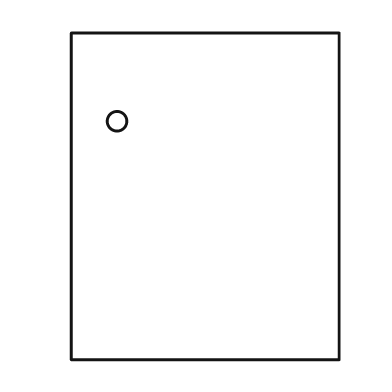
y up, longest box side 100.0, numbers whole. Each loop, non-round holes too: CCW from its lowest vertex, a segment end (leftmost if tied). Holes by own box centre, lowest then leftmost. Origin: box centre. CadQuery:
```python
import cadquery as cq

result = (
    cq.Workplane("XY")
    .moveTo(-41.0, -50.0)
    .lineTo(41.0, -50.0)
    .lineTo(41.0, 50.0)
    .lineTo(-41.0, 50.0)
    .close()
    .moveTo(-27.0, 23.0)
    .circle(3.0)
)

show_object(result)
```